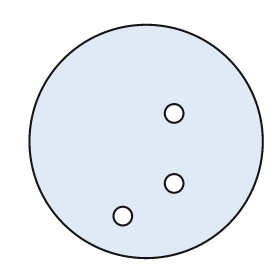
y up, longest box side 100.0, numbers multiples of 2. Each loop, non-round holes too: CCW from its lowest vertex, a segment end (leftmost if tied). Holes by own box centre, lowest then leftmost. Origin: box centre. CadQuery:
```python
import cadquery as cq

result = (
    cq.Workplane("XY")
    .moveTo(0.0, 0.0)
    .circle(50.0)
    .moveTo(-10.0, -32.0)
    .circle(4.0)
    .moveTo(12.0, -18.0)
    .circle(4.0)
    .moveTo(12.0, 12.0)
    .circle(4.0)
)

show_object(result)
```